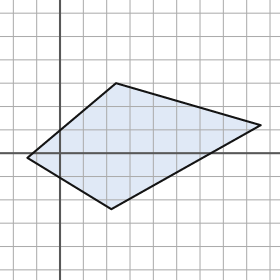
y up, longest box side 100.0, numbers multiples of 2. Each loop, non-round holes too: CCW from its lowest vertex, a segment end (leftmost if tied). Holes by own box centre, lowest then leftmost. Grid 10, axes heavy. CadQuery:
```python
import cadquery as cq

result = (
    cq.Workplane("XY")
    .moveTo(22.0, -24.0)
    .lineTo(86.0, 12.0)
    .lineTo(24.0, 30.0)
    .lineTo(-14.0, -2.0)
    .close()
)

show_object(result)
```